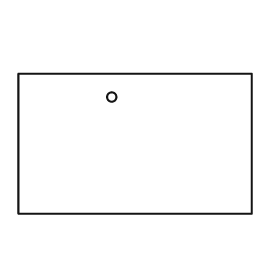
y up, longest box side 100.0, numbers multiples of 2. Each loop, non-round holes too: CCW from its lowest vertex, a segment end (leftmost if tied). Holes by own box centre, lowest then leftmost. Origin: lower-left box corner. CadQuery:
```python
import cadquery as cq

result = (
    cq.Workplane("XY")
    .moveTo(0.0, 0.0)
    .lineTo(100.0, 0.0)
    .lineTo(100.0, 60.0)
    .lineTo(0.0, 60.0)
    .close()
    .moveTo(40.0, 50.0)
    .circle(2.0)
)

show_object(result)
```